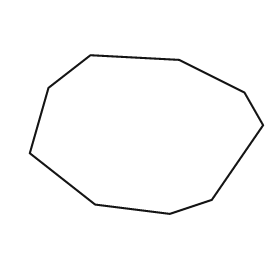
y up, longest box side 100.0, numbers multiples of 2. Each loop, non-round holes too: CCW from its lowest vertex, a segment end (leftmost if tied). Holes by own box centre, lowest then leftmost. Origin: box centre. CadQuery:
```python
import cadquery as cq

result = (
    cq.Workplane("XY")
    .moveTo(10.0, -34.0)
    .lineTo(28.0, -28.0)
    .lineTo(50.0, 4.0)
    .lineTo(42.0, 18.0)
    .lineTo(14.0, 32.0)
    .lineTo(-24.0, 34.0)
    .lineTo(-42.0, 20.0)
    .lineTo(-50.0, -8.0)
    .lineTo(-22.0, -30.0)
    .close()
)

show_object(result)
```